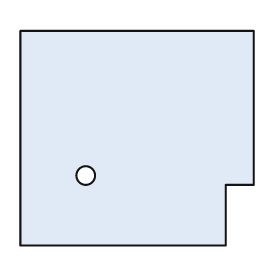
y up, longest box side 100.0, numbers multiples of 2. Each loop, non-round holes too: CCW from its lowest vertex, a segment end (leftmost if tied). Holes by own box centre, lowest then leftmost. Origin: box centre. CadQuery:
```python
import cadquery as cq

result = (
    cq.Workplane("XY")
    .moveTo(-50.0, -46.0)
    .lineTo(38.0, -46.0)
    .lineTo(38.0, -20.0)
    .lineTo(50.0, -20.0)
    .lineTo(50.0, 46.0)
    .lineTo(-50.0, 46.0)
    .close()
    .moveTo(-22.0, -16.0)
    .circle(4.0)
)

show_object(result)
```